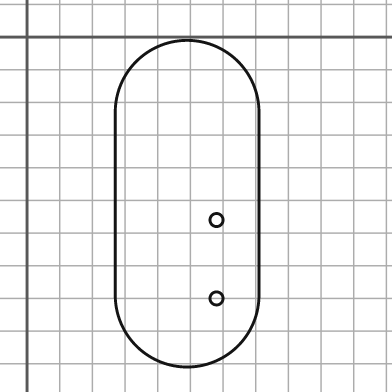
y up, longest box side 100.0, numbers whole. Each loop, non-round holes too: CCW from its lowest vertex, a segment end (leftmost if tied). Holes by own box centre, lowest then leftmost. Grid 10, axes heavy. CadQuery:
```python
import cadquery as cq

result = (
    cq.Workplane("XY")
    .moveTo(27.0, -79.0)
    .threePointArc((49.0, -101.0), (71.0, -79.0))
    .lineTo(71.0, -23.0)
    .threePointArc((49.0, -1.0), (27.0, -23.0))
    .close()
    .moveTo(58.0, -80.0)
    .circle(2.0)
    .moveTo(58.0, -56.0)
    .circle(2.0)
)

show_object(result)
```